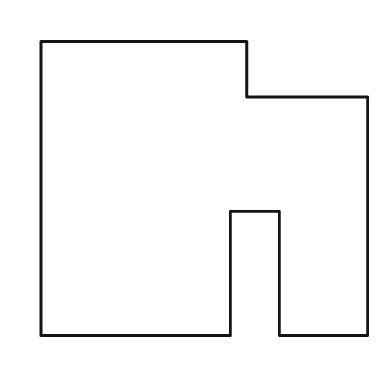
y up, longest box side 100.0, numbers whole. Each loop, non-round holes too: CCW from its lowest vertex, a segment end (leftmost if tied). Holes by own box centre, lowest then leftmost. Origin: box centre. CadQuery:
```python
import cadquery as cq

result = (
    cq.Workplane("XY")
    .moveTo(-50.0, -45.0)
    .lineTo(8.0, -45.0)
    .lineTo(8.0, -7.0)
    .lineTo(23.0, -7.0)
    .lineTo(23.0, -45.0)
    .lineTo(50.0, -45.0)
    .lineTo(50.0, 28.0)
    .lineTo(13.0, 28.0)
    .lineTo(13.0, 45.0)
    .lineTo(-50.0, 45.0)
    .close()
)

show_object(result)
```